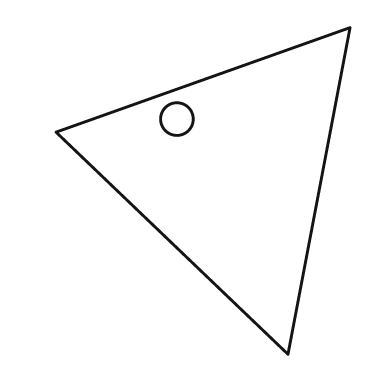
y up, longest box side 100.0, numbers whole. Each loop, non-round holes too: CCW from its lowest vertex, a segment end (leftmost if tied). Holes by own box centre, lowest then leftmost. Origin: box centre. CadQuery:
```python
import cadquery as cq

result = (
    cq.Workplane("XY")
    .moveTo(26.0, -50.0)
    .lineTo(45.0, 50.0)
    .lineTo(-45.0, 18.0)
    .close()
    .moveTo(-8.0, 22.0)
    .circle(5.0)
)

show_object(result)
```